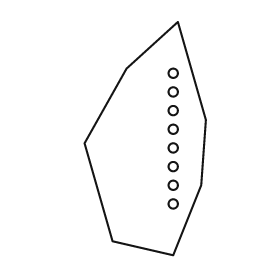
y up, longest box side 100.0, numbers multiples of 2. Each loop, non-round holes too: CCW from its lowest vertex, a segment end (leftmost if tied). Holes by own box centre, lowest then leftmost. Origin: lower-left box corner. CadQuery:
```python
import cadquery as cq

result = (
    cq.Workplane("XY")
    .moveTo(38.0, 0.0)
    .lineTo(50.0, 30.0)
    .lineTo(52.0, 58.0)
    .lineTo(40.0, 100.0)
    .lineTo(18.0, 80.0)
    .lineTo(0.0, 48.0)
    .lineTo(12.0, 6.0)
    .close()
    .moveTo(38.0, 22.0)
    .circle(2.0)
    .moveTo(38.0, 30.0)
    .circle(2.0)
    .moveTo(38.0, 38.0)
    .circle(2.0)
    .moveTo(38.0, 46.0)
    .circle(2.0)
    .moveTo(38.0, 54.0)
    .circle(2.0)
    .moveTo(38.0, 62.0)
    .circle(2.0)
    .moveTo(38.0, 70.0)
    .circle(2.0)
    .moveTo(38.0, 78.0)
    .circle(2.0)
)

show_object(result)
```